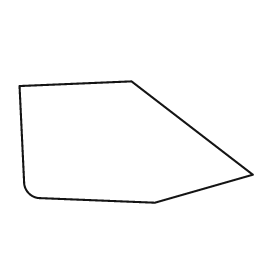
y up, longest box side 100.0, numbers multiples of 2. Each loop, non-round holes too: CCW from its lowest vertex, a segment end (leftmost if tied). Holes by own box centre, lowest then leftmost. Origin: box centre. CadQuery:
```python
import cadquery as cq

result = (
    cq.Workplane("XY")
    .moveTo(8.0, -26.0)
    .lineTo(50.0, -14.0)
    .lineTo(-2.0, 26.0)
    .lineTo(-50.0, 24.0)
    .lineTo(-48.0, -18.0)
    .threePointArc((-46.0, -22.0), (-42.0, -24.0))
    .close()
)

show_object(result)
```